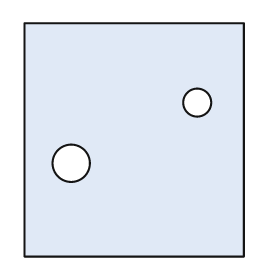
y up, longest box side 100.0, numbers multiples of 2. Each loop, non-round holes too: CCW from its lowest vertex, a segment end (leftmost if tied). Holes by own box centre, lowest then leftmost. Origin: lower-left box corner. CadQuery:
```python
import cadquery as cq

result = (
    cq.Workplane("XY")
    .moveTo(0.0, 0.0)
    .lineTo(94.0, 0.0)
    .lineTo(94.0, 100.0)
    .lineTo(0.0, 100.0)
    .close()
    .moveTo(20.0, 40.0)
    .circle(8.0)
    .moveTo(74.0, 66.0)
    .circle(6.0)
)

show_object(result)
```